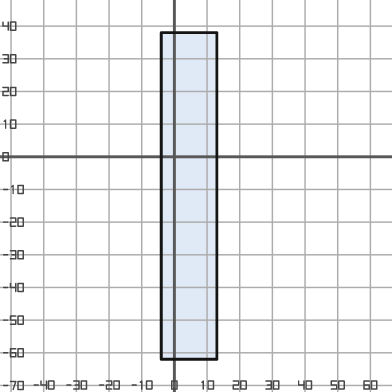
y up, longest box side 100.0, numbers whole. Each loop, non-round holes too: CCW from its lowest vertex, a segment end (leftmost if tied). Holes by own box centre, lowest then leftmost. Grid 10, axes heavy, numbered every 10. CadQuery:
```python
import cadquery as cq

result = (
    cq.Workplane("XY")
    .moveTo(-4.0, -62.0)
    .lineTo(13.0, -62.0)
    .lineTo(13.0, 38.0)
    .lineTo(-4.0, 38.0)
    .close()
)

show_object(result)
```